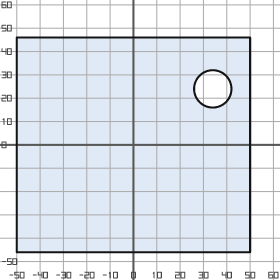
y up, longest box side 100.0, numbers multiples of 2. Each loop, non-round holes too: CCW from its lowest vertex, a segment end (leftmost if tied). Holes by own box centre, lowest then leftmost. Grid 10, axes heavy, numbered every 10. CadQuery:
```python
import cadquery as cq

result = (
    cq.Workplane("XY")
    .moveTo(-50.0, -46.0)
    .lineTo(50.0, -46.0)
    .lineTo(50.0, 46.0)
    .lineTo(-50.0, 46.0)
    .close()
    .moveTo(34.0, 24.0)
    .circle(8.0)
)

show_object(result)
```